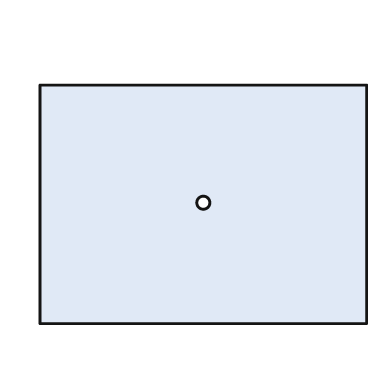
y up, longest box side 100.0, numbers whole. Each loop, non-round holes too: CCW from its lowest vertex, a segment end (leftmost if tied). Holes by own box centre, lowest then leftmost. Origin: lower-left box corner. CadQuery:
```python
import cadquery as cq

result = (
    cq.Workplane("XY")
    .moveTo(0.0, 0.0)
    .lineTo(100.0, 0.0)
    .lineTo(100.0, 73.0)
    .lineTo(0.0, 73.0)
    .close()
    .moveTo(50.0, 37.0)
    .circle(2.0)
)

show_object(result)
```